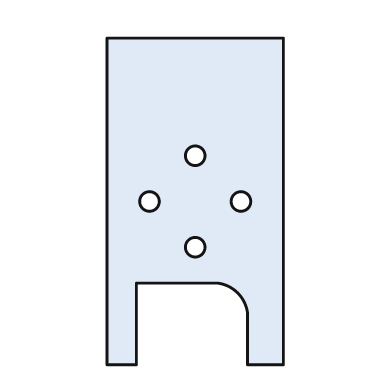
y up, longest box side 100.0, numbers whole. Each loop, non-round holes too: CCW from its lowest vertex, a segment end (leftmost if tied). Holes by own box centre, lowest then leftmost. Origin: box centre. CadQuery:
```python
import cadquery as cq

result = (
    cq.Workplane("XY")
    .moveTo(-27.0, -50.0)
    .lineTo(-18.0, -50.0)
    .lineTo(-18.0, -25.0)
    .lineTo(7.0, -25.0)
    .threePointArc((13.0, -28.0), (16.0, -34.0))
    .lineTo(16.0, -50.0)
    .lineTo(27.0, -50.0)
    .lineTo(27.0, 50.0)
    .lineTo(-27.0, 50.0)
    .close()
    .moveTo(0.0, -14.0)
    .circle(3.0)
    .moveTo(-14.0, 0.0)
    .circle(3.0)
    .moveTo(14.0, 0.0)
    .circle(3.0)
    .moveTo(0.0, 14.0)
    .circle(3.0)
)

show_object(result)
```